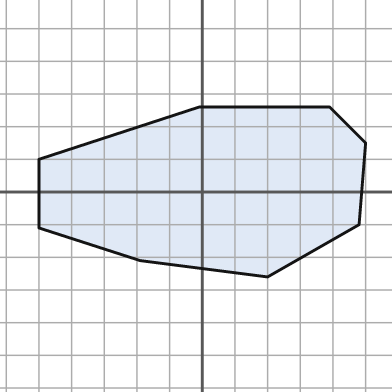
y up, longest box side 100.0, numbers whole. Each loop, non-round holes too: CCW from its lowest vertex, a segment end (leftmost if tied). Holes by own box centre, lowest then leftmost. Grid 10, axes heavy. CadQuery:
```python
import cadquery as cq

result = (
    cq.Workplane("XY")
    .moveTo(20.0, -26.0)
    .lineTo(48.0, -10.0)
    .lineTo(50.0, 15.0)
    .lineTo(39.0, 26.0)
    .lineTo(-1.0, 26.0)
    .lineTo(-50.0, 10.0)
    .lineTo(-50.0, -11.0)
    .lineTo(-19.0, -21.0)
    .close()
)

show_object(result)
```